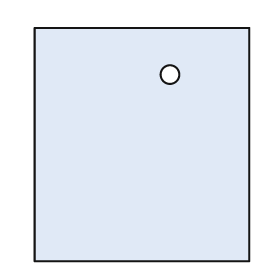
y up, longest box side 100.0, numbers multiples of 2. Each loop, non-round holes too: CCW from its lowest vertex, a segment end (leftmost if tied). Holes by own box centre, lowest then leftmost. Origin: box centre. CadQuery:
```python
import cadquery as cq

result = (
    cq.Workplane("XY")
    .moveTo(-46.0, -50.0)
    .lineTo(46.0, -50.0)
    .lineTo(46.0, 50.0)
    .lineTo(-46.0, 50.0)
    .close()
    .moveTo(12.0, 30.0)
    .circle(4.0)
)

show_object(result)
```